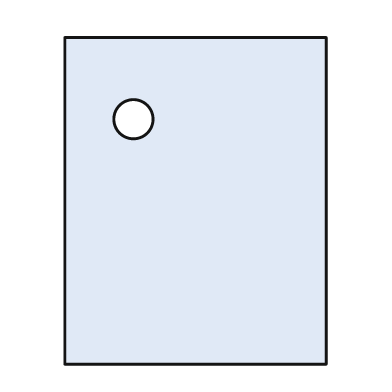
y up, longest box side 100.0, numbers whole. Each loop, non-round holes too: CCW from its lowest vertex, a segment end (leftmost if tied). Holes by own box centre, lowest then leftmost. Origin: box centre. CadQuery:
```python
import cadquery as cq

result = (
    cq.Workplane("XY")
    .moveTo(-40.0, -50.0)
    .lineTo(40.0, -50.0)
    .lineTo(40.0, 50.0)
    .lineTo(-40.0, 50.0)
    .close()
    .moveTo(-19.0, 25.0)
    .circle(6.0)
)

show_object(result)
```